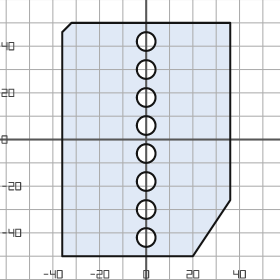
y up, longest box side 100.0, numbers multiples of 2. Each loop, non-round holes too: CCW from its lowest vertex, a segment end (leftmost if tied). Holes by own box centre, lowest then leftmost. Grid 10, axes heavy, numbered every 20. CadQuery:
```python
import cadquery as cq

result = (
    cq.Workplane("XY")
    .moveTo(-36.0, -50.0)
    .lineTo(20.0, -50.0)
    .lineTo(36.0, -26.0)
    .lineTo(36.0, 50.0)
    .lineTo(-32.0, 50.0)
    .lineTo(-36.0, 46.0)
    .close()
    .moveTo(0.0, -42.0)
    .circle(4.0)
    .moveTo(0.0, -30.0)
    .circle(4.0)
    .moveTo(0.0, -18.0)
    .circle(4.0)
    .moveTo(0.0, -6.0)
    .circle(4.0)
    .moveTo(0.0, 6.0)
    .circle(4.0)
    .moveTo(0.0, 18.0)
    .circle(4.0)
    .moveTo(0.0, 30.0)
    .circle(4.0)
    .moveTo(0.0, 42.0)
    .circle(4.0)
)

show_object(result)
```